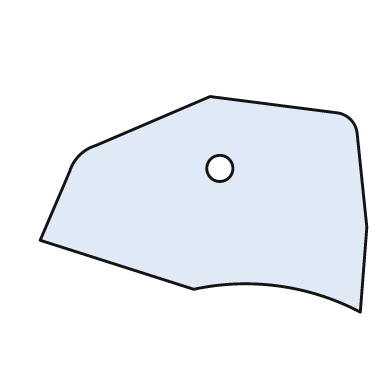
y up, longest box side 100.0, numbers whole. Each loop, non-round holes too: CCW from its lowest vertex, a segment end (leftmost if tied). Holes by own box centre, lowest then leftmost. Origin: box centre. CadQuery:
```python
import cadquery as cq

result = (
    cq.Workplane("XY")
    .moveTo(48.0, -33.0)
    .lineTo(50.0, -7.0)
    .lineTo(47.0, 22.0)
    .threePointArc((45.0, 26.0), (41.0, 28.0))
    .lineTo(2.0, 33.0)
    .lineTo(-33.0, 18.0)
    .threePointArc((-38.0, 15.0), (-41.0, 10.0))
    .lineTo(-50.0, -11.0)
    .lineTo(-3.0, -26.0)
    .threePointArc((23.0, -25.0), (48.0, -33.0))
    .close()
    .moveTo(5.0, 11.0)
    .circle(4.0)
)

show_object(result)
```